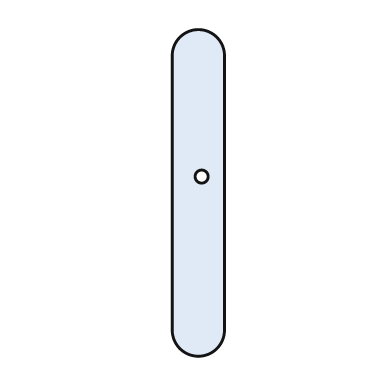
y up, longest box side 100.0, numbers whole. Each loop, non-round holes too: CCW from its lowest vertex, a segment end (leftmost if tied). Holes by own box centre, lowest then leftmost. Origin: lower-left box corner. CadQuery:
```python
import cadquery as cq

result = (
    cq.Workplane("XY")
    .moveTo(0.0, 8.0)
    .threePointArc((8.0, 0.0), (16.0, 8.0))
    .lineTo(16.0, 92.0)
    .threePointArc((8.0, 100.0), (0.0, 92.0))
    .close()
    .moveTo(9.0, 55.0)
    .circle(2.0)
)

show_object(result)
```